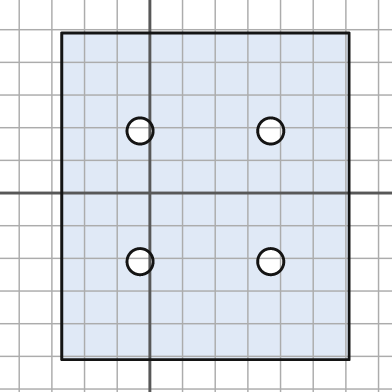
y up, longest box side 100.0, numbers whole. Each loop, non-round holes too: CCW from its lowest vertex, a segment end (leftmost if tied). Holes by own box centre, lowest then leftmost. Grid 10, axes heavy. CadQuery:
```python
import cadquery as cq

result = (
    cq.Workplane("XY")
    .moveTo(-27.0, -51.0)
    .lineTo(61.0, -51.0)
    .lineTo(61.0, 49.0)
    .lineTo(-27.0, 49.0)
    .close()
    .moveTo(-3.0, -21.0)
    .circle(4.0)
    .moveTo(37.0, -21.0)
    .circle(4.0)
    .moveTo(-3.0, 19.0)
    .circle(4.0)
    .moveTo(37.0, 19.0)
    .circle(4.0)
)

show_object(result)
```